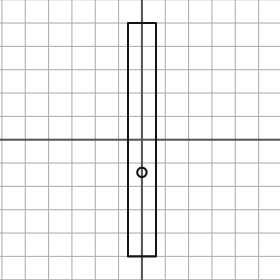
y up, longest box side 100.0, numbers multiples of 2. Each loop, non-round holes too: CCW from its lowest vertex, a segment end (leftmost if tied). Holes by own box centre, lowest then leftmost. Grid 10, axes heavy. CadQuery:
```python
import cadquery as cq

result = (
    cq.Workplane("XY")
    .moveTo(-6.0, -50.0)
    .lineTo(6.0, -50.0)
    .lineTo(6.0, 50.0)
    .lineTo(-6.0, 50.0)
    .close()
    .moveTo(0.0, -14.0)
    .circle(2.0)
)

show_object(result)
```